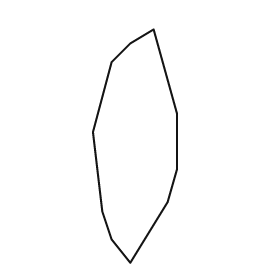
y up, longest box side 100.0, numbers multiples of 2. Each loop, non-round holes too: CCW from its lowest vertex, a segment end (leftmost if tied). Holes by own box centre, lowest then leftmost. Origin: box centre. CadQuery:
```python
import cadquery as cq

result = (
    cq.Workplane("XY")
    .moveTo(-2.0, -50.0)
    .lineTo(14.0, -24.0)
    .lineTo(18.0, -10.0)
    .lineTo(18.0, 14.0)
    .lineTo(8.0, 50.0)
    .lineTo(-2.0, 44.0)
    .lineTo(-10.0, 36.0)
    .lineTo(-18.0, 6.0)
    .lineTo(-14.0, -28.0)
    .lineTo(-10.0, -40.0)
    .close()
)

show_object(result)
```